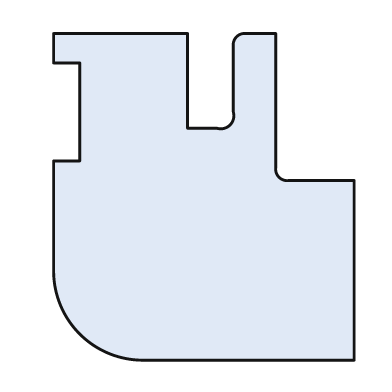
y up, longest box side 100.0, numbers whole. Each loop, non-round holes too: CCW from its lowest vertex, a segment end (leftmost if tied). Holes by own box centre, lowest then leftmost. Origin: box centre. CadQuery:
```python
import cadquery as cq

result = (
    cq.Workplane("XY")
    .moveTo(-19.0, -50.0)
    .lineTo(46.0, -50.0)
    .lineTo(46.0, 5.0)
    .lineTo(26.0, 5.0)
    .threePointArc((23.0, 6.0), (22.0, 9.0))
    .lineTo(22.0, 50.0)
    .lineTo(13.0, 50.0)
    .threePointArc((10.0, 49.0), (9.0, 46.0))
    .lineTo(9.0, 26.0)
    .threePointArc((8.0, 22.0), (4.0, 21.0))
    .lineTo(-5.0, 21.0)
    .lineTo(-5.0, 50.0)
    .lineTo(-46.0, 50.0)
    .lineTo(-46.0, 41.0)
    .lineTo(-38.0, 41.0)
    .lineTo(-38.0, 11.0)
    .lineTo(-46.0, 11.0)
    .lineTo(-46.0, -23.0)
    .threePointArc((-38.0, -42.0), (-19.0, -50.0))
    .close()
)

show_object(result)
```